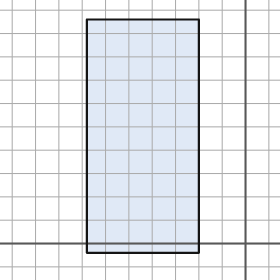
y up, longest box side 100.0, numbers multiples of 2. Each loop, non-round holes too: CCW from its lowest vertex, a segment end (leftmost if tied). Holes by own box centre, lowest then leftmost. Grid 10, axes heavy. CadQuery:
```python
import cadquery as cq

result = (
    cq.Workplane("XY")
    .moveTo(-68.0, -4.0)
    .lineTo(-20.0, -4.0)
    .lineTo(-20.0, 96.0)
    .lineTo(-68.0, 96.0)
    .close()
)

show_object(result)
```